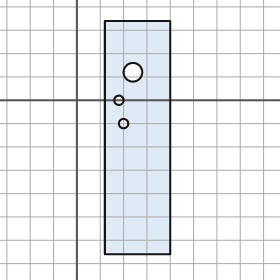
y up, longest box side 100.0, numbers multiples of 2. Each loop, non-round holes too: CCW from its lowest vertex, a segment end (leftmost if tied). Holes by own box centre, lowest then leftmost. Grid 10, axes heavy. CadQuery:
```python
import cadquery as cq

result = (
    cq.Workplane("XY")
    .moveTo(12.0, -66.0)
    .lineTo(40.0, -66.0)
    .lineTo(40.0, 34.0)
    .lineTo(12.0, 34.0)
    .close()
    .moveTo(20.0, -10.0)
    .circle(2.0)
    .moveTo(18.0, 0.0)
    .circle(2.0)
    .moveTo(24.0, 12.0)
    .circle(4.0)
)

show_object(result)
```